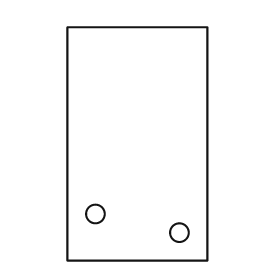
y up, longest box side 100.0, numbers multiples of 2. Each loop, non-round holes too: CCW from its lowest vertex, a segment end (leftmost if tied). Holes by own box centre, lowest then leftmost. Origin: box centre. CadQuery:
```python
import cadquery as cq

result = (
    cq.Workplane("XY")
    .moveTo(-30.0, -50.0)
    .lineTo(30.0, -50.0)
    .lineTo(30.0, 50.0)
    .lineTo(-30.0, 50.0)
    .close()
    .moveTo(18.0, -38.0)
    .circle(4.0)
    .moveTo(-18.0, -30.0)
    .circle(4.0)
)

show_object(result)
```